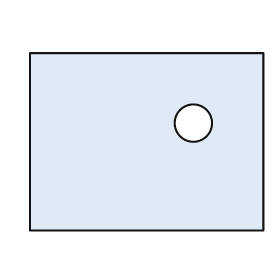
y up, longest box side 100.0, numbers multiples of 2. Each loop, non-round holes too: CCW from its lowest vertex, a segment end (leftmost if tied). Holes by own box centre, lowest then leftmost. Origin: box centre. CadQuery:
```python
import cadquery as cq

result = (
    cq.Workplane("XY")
    .moveTo(-50.0, -38.0)
    .lineTo(50.0, -38.0)
    .lineTo(50.0, 38.0)
    .lineTo(-50.0, 38.0)
    .close()
    .moveTo(20.0, 8.0)
    .circle(8.0)
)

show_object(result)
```